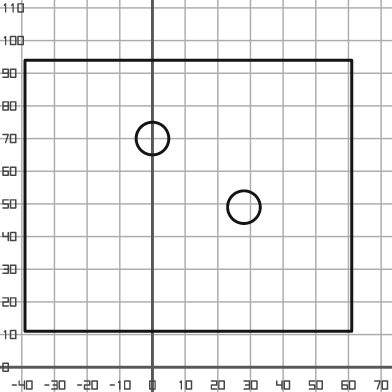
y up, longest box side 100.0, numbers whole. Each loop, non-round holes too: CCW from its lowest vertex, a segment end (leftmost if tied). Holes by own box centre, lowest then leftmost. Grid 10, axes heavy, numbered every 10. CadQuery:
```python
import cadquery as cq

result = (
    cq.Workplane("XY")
    .moveTo(-39.0, 11.0)
    .lineTo(61.0, 11.0)
    .lineTo(61.0, 94.0)
    .lineTo(-39.0, 94.0)
    .close()
    .moveTo(28.0, 49.0)
    .circle(5.0)
    .moveTo(0.0, 70.0)
    .circle(5.0)
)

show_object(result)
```